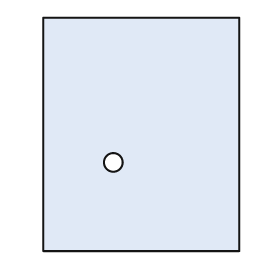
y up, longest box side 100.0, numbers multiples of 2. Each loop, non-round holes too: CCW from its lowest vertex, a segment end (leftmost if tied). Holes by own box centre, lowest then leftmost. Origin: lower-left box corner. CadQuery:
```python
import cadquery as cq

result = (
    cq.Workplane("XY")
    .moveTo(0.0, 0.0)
    .lineTo(84.0, 0.0)
    .lineTo(84.0, 100.0)
    .lineTo(0.0, 100.0)
    .close()
    .moveTo(30.0, 38.0)
    .circle(4.0)
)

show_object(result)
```